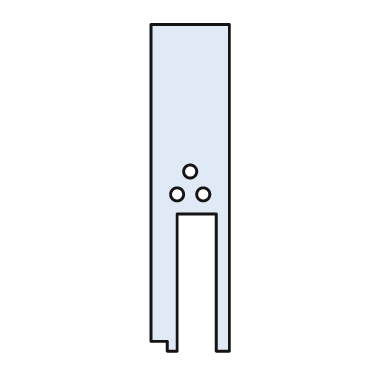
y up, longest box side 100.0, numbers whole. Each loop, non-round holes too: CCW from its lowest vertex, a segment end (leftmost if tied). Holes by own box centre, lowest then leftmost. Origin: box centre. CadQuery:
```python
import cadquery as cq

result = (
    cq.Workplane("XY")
    .moveTo(-7.0, -50.0)
    .lineTo(-4.0, -50.0)
    .lineTo(-4.0, -8.0)
    .lineTo(8.0, -8.0)
    .lineTo(8.0, -50.0)
    .lineTo(12.0, -50.0)
    .lineTo(12.0, 50.0)
    .lineTo(-12.0, 50.0)
    .lineTo(-12.0, -47.0)
    .lineTo(-7.0, -47.0)
    .close()
    .moveTo(-4.0, -2.0)
    .circle(2.0)
    .moveTo(4.0, -2.0)
    .circle(2.0)
    .moveTo(0.0, 5.0)
    .circle(2.0)
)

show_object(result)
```